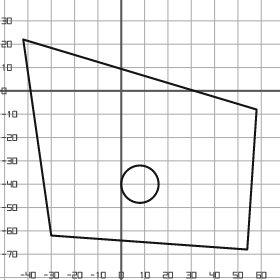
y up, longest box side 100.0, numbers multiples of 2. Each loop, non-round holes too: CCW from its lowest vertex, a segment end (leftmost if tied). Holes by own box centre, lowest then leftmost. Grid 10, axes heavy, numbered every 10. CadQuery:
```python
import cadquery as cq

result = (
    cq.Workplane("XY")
    .moveTo(54.0, -68.0)
    .lineTo(58.0, -8.0)
    .lineTo(-42.0, 22.0)
    .lineTo(-30.0, -62.0)
    .close()
    .moveTo(8.0, -40.0)
    .circle(8.0)
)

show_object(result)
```